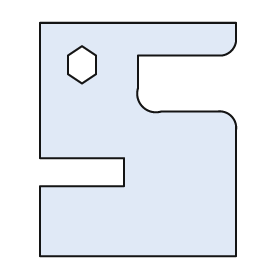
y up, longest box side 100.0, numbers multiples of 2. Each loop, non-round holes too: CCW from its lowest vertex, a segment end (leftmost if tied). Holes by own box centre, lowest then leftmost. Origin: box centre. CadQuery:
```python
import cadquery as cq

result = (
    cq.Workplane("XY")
    .moveTo(-42.0, -50.0)
    .lineTo(42.0, -50.0)
    .lineTo(42.0, 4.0)
    .threePointArc((40.0, 10.0), (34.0, 12.0))
    .lineTo(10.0, 12.0)
    .threePointArc((2.0, 14.0), (0.0, 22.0))
    .lineTo(0.0, 36.0)
    .lineTo(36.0, 36.0)
    .threePointArc((40.0, 38.0), (42.0, 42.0))
    .lineTo(42.0, 50.0)
    .lineTo(-42.0, 50.0)
    .lineTo(-42.0, -8.0)
    .lineTo(-6.0, -8.0)
    .lineTo(-6.0, -20.0)
    .lineTo(-42.0, -20.0)
    .close()
    .moveTo(-24.0, 24.0)
    .lineTo(-18.0, 28.0)
    .lineTo(-18.0, 36.0)
    .lineTo(-24.0, 40.0)
    .lineTo(-30.0, 36.0)
    .lineTo(-30.0, 28.0)
    .close()
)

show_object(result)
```